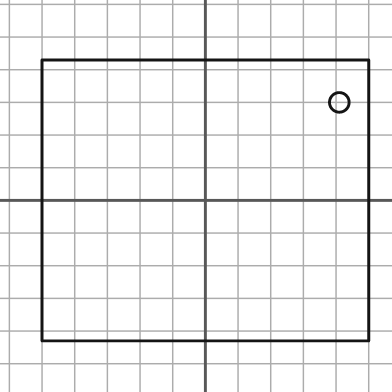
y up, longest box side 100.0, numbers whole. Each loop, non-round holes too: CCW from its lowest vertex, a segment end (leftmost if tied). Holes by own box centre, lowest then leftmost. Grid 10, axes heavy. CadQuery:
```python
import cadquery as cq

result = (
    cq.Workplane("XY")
    .moveTo(-50.0, -43.0)
    .lineTo(50.0, -43.0)
    .lineTo(50.0, 43.0)
    .lineTo(-50.0, 43.0)
    .close()
    .moveTo(41.0, 30.0)
    .circle(3.0)
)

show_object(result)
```